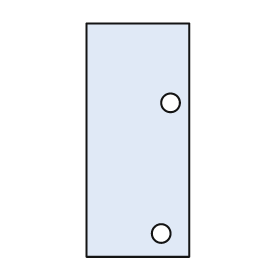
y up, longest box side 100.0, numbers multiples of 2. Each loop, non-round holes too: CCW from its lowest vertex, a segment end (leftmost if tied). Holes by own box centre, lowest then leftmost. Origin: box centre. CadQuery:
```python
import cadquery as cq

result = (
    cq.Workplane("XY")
    .moveTo(-22.0, -50.0)
    .lineTo(22.0, -50.0)
    .lineTo(22.0, 50.0)
    .lineTo(-22.0, 50.0)
    .close()
    .moveTo(10.0, -40.0)
    .circle(4.0)
    .moveTo(14.0, 16.0)
    .circle(4.0)
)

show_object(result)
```